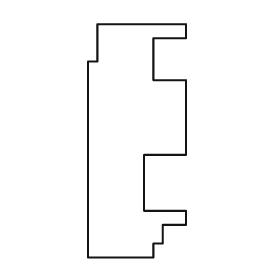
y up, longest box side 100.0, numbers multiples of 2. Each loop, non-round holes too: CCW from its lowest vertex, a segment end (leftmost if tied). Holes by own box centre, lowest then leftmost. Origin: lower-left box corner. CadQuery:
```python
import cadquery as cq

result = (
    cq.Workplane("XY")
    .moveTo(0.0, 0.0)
    .lineTo(28.0, 0.0)
    .lineTo(28.0, 6.0)
    .lineTo(32.0, 6.0)
    .lineTo(32.0, 14.0)
    .lineTo(42.0, 14.0)
    .lineTo(42.0, 20.0)
    .lineTo(24.0, 20.0)
    .lineTo(24.0, 44.0)
    .lineTo(42.0, 44.0)
    .lineTo(42.0, 76.0)
    .lineTo(28.0, 76.0)
    .lineTo(28.0, 94.0)
    .lineTo(42.0, 94.0)
    .lineTo(42.0, 100.0)
    .lineTo(4.0, 100.0)
    .lineTo(4.0, 84.0)
    .lineTo(0.0, 84.0)
    .close()
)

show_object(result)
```